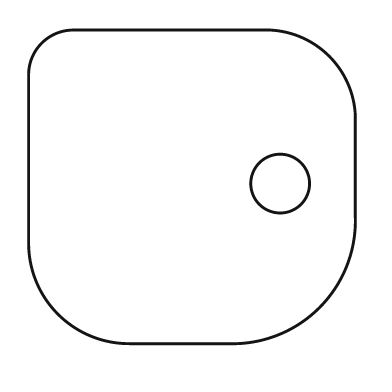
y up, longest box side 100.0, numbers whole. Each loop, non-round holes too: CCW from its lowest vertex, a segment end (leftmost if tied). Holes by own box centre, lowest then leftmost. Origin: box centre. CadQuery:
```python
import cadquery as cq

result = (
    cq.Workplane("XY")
    .moveTo(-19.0, -48.0)
    .lineTo(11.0, -48.0)
    .threePointArc((39.0, -37.0), (50.0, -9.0))
    .lineTo(50.0, 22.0)
    .threePointArc((42.0, 40.0), (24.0, 48.0))
    .lineTo(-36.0, 48.0)
    .threePointArc((-46.0, 44.0), (-50.0, 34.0))
    .lineTo(-50.0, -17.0)
    .threePointArc((-41.0, -39.0), (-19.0, -48.0))
    .close()
    .moveTo(27.0, 1.0)
    .circle(9.0)
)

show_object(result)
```